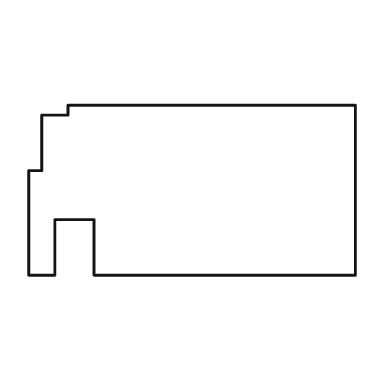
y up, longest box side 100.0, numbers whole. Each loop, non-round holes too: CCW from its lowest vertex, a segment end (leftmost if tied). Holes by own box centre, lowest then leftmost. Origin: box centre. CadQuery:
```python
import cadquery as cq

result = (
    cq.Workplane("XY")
    .moveTo(-50.0, -26.0)
    .lineTo(-42.0, -26.0)
    .lineTo(-42.0, -9.0)
    .lineTo(-30.0, -9.0)
    .lineTo(-30.0, -26.0)
    .lineTo(50.0, -26.0)
    .lineTo(50.0, 26.0)
    .lineTo(-38.0, 26.0)
    .lineTo(-38.0, 23.0)
    .lineTo(-46.0, 23.0)
    .lineTo(-46.0, 6.0)
    .lineTo(-50.0, 6.0)
    .close()
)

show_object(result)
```